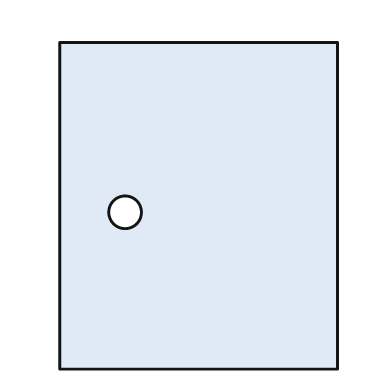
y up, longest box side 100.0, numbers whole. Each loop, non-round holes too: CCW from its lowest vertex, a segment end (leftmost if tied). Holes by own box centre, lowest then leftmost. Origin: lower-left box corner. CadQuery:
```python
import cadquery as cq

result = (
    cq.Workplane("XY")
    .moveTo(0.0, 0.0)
    .lineTo(85.0, 0.0)
    .lineTo(85.0, 100.0)
    .lineTo(0.0, 100.0)
    .close()
    .moveTo(20.0, 48.0)
    .circle(5.0)
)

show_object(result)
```